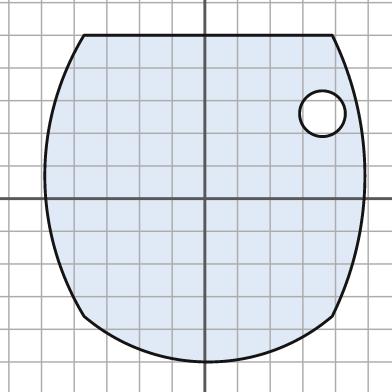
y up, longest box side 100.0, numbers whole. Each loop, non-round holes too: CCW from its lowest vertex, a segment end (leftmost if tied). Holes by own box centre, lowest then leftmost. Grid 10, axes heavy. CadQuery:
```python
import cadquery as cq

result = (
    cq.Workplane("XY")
    .moveTo(-37.0, -36.0)
    .threePointArc((1.0, -50.0), (39.0, -36.0))
    .threePointArc((49.0, 7.0), (39.0, 50.0))
    .lineTo(-37.0, 50.0)
    .threePointArc((-49.0, 7.0), (-37.0, -36.0))
    .close()
    .moveTo(36.0, 26.0)
    .circle(7.0)
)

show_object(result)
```